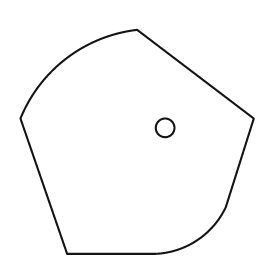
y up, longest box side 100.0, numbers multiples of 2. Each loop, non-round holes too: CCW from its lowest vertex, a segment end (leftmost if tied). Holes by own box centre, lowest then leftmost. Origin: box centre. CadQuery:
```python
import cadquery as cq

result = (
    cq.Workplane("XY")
    .moveTo(-30.0, -48.0)
    .lineTo(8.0, -48.0)
    .threePointArc((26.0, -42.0), (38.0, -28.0))
    .lineTo(50.0, 10.0)
    .lineTo(0.0, 48.0)
    .threePointArc((-30.0, 36.0), (-50.0, 10.0))
    .close()
    .moveTo(12.0, 6.0)
    .circle(4.0)
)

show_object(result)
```